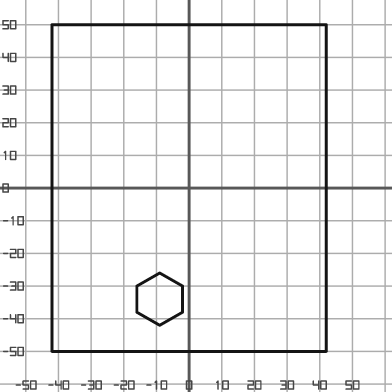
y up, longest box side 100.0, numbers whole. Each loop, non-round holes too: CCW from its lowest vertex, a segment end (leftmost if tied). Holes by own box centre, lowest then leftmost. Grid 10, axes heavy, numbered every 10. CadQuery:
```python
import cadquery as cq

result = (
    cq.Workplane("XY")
    .moveTo(-42.0, -50.0)
    .lineTo(42.0, -50.0)
    .lineTo(42.0, 50.0)
    .lineTo(-42.0, 50.0)
    .close()
    .moveTo(-9.0, -42.0)
    .lineTo(-2.0, -38.0)
    .lineTo(-2.0, -30.0)
    .lineTo(-9.0, -26.0)
    .lineTo(-16.0, -30.0)
    .lineTo(-16.0, -38.0)
    .close()
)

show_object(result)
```